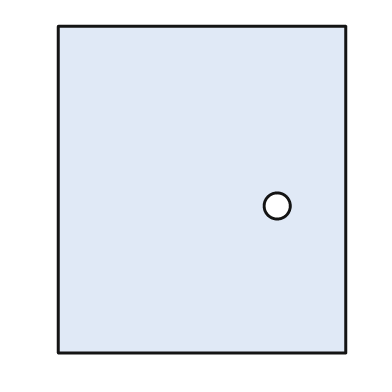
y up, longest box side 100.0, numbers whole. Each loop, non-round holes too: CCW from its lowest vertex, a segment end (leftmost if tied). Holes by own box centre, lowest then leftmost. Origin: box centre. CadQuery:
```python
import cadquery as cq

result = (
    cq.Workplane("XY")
    .moveTo(-44.0, -50.0)
    .lineTo(44.0, -50.0)
    .lineTo(44.0, 50.0)
    .lineTo(-44.0, 50.0)
    .close()
    .moveTo(23.0, -5.0)
    .circle(4.0)
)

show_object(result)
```